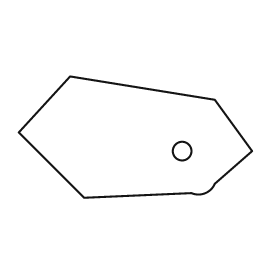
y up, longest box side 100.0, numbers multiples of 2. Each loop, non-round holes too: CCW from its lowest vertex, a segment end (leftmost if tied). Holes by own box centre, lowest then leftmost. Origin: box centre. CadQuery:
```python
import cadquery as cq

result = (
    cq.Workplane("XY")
    .moveTo(-22.0, -26.0)
    .lineTo(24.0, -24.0)
    .threePointArc((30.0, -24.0), (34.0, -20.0))
    .lineTo(50.0, -6.0)
    .lineTo(34.0, 16.0)
    .lineTo(-28.0, 26.0)
    .lineTo(-50.0, 2.0)
    .close()
    .moveTo(20.0, -6.0)
    .circle(4.0)
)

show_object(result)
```